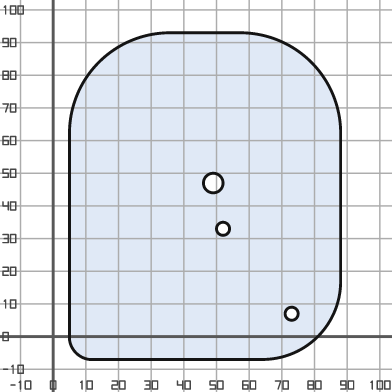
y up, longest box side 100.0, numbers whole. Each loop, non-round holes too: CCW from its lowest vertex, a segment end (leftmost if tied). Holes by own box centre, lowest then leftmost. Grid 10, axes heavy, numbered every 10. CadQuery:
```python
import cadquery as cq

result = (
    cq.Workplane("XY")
    .moveTo(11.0, -7.0)
    .lineTo(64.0, -7.0)
    .threePointArc((81.0, 0.0), (88.0, 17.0))
    .lineTo(88.0, 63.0)
    .threePointArc((79.0, 84.0), (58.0, 93.0))
    .lineTo(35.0, 93.0)
    .threePointArc((14.0, 84.0), (5.0, 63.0))
    .lineTo(5.0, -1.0)
    .threePointArc((7.0, -5.0), (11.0, -7.0))
    .close()
    .moveTo(73.0, 7.0)
    .circle(2.0)
    .moveTo(52.0, 33.0)
    .circle(2.0)
    .moveTo(49.0, 47.0)
    .circle(3.0)
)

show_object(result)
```